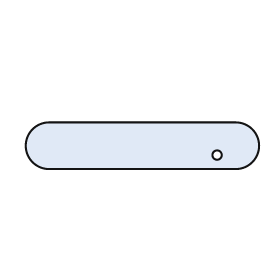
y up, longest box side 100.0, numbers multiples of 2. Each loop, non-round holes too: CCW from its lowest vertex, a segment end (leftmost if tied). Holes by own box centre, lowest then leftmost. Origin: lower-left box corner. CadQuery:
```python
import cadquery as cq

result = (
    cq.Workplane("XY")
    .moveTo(10.0, 0.0)
    .lineTo(90.0, 0.0)
    .threePointArc((100.0, 10.0), (90.0, 20.0))
    .lineTo(10.0, 20.0)
    .threePointArc((0.0, 10.0), (10.0, 0.0))
    .close()
    .moveTo(82.0, 6.0)
    .circle(2.0)
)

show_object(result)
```